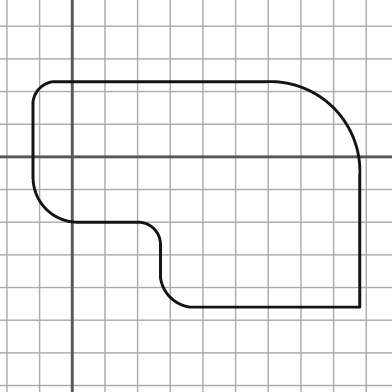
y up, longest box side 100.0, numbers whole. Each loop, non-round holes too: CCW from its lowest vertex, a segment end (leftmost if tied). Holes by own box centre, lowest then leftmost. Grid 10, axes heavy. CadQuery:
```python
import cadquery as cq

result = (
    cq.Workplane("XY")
    .moveTo(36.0, -46.0)
    .lineTo(88.0, -46.0)
    .lineTo(88.0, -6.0)
    .threePointArc((80.0, 15.0), (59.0, 23.0))
    .lineTo(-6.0, 23.0)
    .threePointArc((-10.0, 21.0), (-12.0, 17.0))
    .lineTo(-12.0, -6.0)
    .threePointArc((-8.0, -16.0), (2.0, -20.0))
    .lineTo(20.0, -20.0)
    .threePointArc((25.0, -22.0), (27.0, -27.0))
    .lineTo(27.0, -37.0)
    .threePointArc((30.0, -43.0), (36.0, -46.0))
    .close()
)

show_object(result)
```